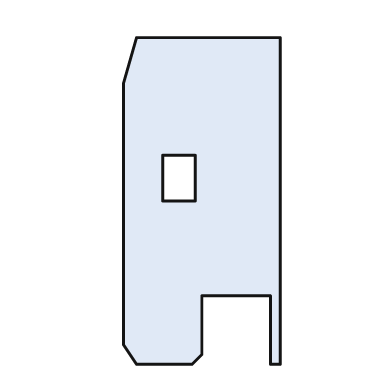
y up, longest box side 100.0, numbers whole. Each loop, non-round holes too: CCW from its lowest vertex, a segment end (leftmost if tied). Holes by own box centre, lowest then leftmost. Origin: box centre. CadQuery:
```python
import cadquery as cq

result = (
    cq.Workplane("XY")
    .moveTo(-20.0, -50.0)
    .lineTo(-3.0, -50.0)
    .lineTo(0.0, -47.0)
    .lineTo(0.0, -29.0)
    .lineTo(21.0, -29.0)
    .lineTo(21.0, -50.0)
    .lineTo(24.0, -50.0)
    .lineTo(24.0, 50.0)
    .lineTo(-20.0, 50.0)
    .lineTo(-24.0, 36.0)
    .lineTo(-24.0, -44.0)
    .close()
    .moveTo(-12.0, 0.0)
    .lineTo(-2.0, 0.0)
    .lineTo(-2.0, 14.0)
    .lineTo(-12.0, 14.0)
    .close()
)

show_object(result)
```